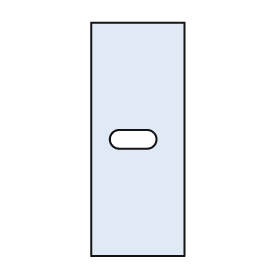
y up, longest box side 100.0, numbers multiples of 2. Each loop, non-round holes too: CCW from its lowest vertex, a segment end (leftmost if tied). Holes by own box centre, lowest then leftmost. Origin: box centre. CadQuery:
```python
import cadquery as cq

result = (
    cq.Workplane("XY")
    .moveTo(-20.0, -50.0)
    .lineTo(20.0, -50.0)
    .lineTo(20.0, 50.0)
    .lineTo(-20.0, 50.0)
    .close()
    .moveTo(-8.0, -4.0)
    .lineTo(4.0, -4.0)
    .threePointArc((8.0, 0.0), (4.0, 4.0))
    .lineTo(-8.0, 4.0)
    .threePointArc((-12.0, 0.0), (-8.0, -4.0))
    .close()
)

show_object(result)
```